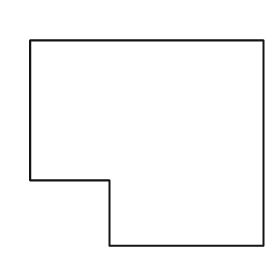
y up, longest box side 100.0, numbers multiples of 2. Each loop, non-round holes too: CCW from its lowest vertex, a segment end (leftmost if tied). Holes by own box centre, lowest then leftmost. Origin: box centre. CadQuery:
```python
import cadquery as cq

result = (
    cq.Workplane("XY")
    .moveTo(-16.0, -44.0)
    .lineTo(50.0, -44.0)
    .lineTo(50.0, 44.0)
    .lineTo(-50.0, 44.0)
    .lineTo(-50.0, -16.0)
    .lineTo(-16.0, -16.0)
    .close()
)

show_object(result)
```